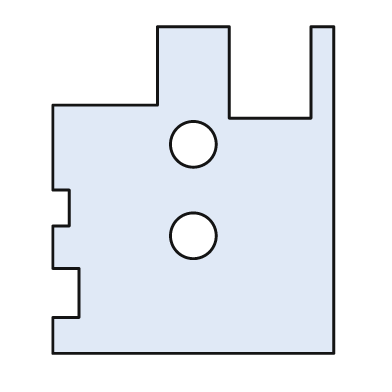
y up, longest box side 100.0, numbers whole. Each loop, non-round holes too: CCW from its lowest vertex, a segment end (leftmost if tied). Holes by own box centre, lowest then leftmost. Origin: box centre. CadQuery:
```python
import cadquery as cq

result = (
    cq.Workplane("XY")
    .moveTo(-43.0, -50.0)
    .lineTo(43.0, -50.0)
    .lineTo(43.0, 50.0)
    .lineTo(36.0, 50.0)
    .lineTo(36.0, 22.0)
    .lineTo(11.0, 22.0)
    .lineTo(11.0, 50.0)
    .lineTo(-11.0, 50.0)
    .lineTo(-11.0, 26.0)
    .lineTo(-43.0, 26.0)
    .lineTo(-43.0, 0.0)
    .lineTo(-38.0, 0.0)
    .lineTo(-38.0, -11.0)
    .lineTo(-43.0, -11.0)
    .lineTo(-43.0, -24.0)
    .lineTo(-35.0, -24.0)
    .lineTo(-35.0, -39.0)
    .lineTo(-43.0, -39.0)
    .close()
    .moveTo(0.0, -14.0)
    .circle(7.0)
    .moveTo(0.0, 14.0)
    .circle(7.0)
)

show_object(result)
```